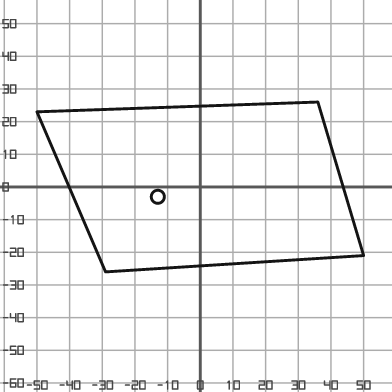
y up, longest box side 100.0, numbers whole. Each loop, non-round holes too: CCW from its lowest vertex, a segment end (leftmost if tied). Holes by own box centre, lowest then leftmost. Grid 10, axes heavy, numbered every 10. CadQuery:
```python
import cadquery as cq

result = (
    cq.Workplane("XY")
    .moveTo(-29.0, -26.0)
    .lineTo(50.0, -21.0)
    .lineTo(36.0, 26.0)
    .lineTo(-50.0, 23.0)
    .close()
    .moveTo(-13.0, -3.0)
    .circle(2.0)
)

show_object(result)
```